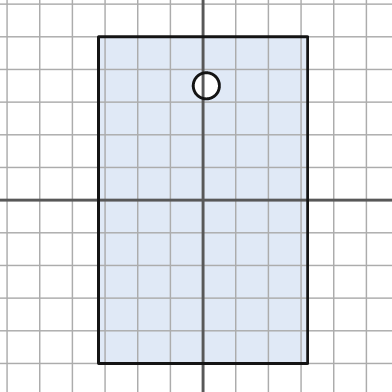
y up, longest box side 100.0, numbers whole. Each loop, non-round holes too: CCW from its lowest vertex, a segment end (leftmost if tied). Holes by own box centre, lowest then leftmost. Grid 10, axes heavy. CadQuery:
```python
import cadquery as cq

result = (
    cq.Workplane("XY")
    .moveTo(-32.0, -50.0)
    .lineTo(32.0, -50.0)
    .lineTo(32.0, 50.0)
    .lineTo(-32.0, 50.0)
    .close()
    .moveTo(1.0, 35.0)
    .circle(4.0)
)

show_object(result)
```